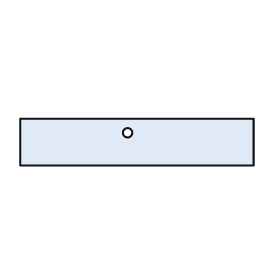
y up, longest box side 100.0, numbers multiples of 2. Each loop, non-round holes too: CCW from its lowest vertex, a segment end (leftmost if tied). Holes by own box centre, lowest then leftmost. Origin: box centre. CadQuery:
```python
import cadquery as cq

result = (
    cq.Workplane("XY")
    .moveTo(-50.0, -10.0)
    .lineTo(50.0, -10.0)
    .lineTo(50.0, 10.0)
    .lineTo(-50.0, 10.0)
    .close()
    .moveTo(-4.0, 4.0)
    .circle(2.0)
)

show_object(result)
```